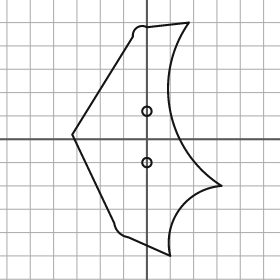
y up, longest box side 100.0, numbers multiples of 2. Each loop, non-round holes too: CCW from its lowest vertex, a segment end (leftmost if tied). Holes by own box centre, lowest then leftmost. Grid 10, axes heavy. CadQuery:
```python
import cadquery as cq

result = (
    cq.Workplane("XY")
    .moveTo(10.0, -50.0)
    .threePointArc((14.0, -30.0), (32.0, -20.0))
    .threePointArc((10.0, 12.0), (18.0, 50.0))
    .lineTo(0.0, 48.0)
    .threePointArc((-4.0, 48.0), (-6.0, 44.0))
    .lineTo(-32.0, 2.0)
    .lineTo(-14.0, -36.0)
    .threePointArc((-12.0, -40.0), (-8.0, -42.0))
    .close()
    .moveTo(0.0, -10.0)
    .circle(2.0)
    .moveTo(0.0, 12.0)
    .circle(2.0)
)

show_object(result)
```